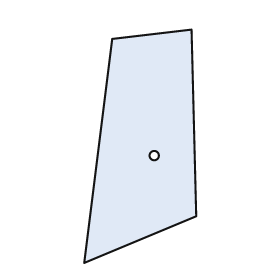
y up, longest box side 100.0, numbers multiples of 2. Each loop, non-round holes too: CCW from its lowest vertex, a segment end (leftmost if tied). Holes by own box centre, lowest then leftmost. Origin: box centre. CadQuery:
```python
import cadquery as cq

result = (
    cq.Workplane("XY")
    .moveTo(-24.0, -50.0)
    .lineTo(24.0, -30.0)
    .lineTo(22.0, 50.0)
    .lineTo(-12.0, 46.0)
    .close()
    .moveTo(6.0, -4.0)
    .circle(2.0)
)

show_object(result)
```